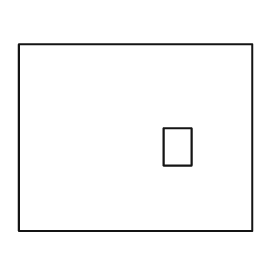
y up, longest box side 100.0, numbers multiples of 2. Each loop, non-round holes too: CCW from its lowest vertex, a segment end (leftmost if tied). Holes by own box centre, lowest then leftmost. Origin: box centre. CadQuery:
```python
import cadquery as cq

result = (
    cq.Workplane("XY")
    .moveTo(-50.0, -40.0)
    .lineTo(50.0, -40.0)
    .lineTo(50.0, 40.0)
    .lineTo(-50.0, 40.0)
    .close()
    .moveTo(12.0, -12.0)
    .lineTo(24.0, -12.0)
    .lineTo(24.0, 4.0)
    .lineTo(12.0, 4.0)
    .close()
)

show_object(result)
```